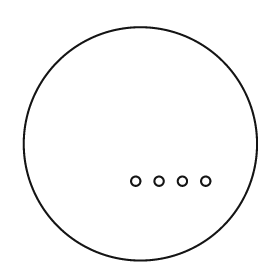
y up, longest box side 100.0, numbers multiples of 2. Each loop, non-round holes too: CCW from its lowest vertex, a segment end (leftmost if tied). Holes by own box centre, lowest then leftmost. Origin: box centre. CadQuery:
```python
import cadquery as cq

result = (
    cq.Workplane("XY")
    .moveTo(0.0, 0.0)
    .circle(50.0)
    .moveTo(-2.0, -16.0)
    .circle(2.0)
    .moveTo(8.0, -16.0)
    .circle(2.0)
    .moveTo(18.0, -16.0)
    .circle(2.0)
    .moveTo(28.0, -16.0)
    .circle(2.0)
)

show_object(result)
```